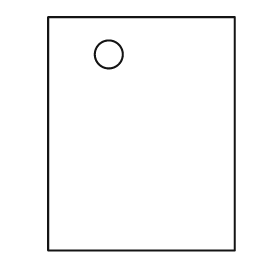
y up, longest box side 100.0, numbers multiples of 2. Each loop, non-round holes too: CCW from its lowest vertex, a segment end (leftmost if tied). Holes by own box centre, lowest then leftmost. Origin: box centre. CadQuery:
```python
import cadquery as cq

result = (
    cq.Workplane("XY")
    .moveTo(-40.0, -50.0)
    .lineTo(40.0, -50.0)
    .lineTo(40.0, 50.0)
    .lineTo(-40.0, 50.0)
    .close()
    .moveTo(-14.0, 34.0)
    .circle(6.0)
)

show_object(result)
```